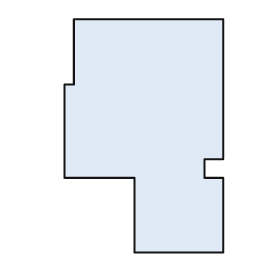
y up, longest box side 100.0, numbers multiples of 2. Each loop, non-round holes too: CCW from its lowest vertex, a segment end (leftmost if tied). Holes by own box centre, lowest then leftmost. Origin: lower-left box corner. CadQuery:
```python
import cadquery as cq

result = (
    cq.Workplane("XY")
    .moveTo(30.0, 0.0)
    .lineTo(68.0, 0.0)
    .lineTo(68.0, 32.0)
    .lineTo(60.0, 32.0)
    .lineTo(60.0, 40.0)
    .lineTo(68.0, 40.0)
    .lineTo(68.0, 100.0)
    .lineTo(4.0, 100.0)
    .lineTo(4.0, 72.0)
    .lineTo(0.0, 72.0)
    .lineTo(0.0, 32.0)
    .lineTo(30.0, 32.0)
    .close()
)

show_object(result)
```